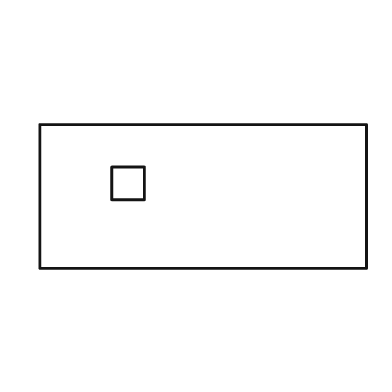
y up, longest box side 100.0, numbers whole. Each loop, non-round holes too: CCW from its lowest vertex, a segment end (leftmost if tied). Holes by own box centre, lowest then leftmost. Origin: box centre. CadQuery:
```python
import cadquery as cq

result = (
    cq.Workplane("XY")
    .moveTo(-50.0, -22.0)
    .lineTo(50.0, -22.0)
    .lineTo(50.0, 22.0)
    .lineTo(-50.0, 22.0)
    .close()
    .moveTo(-28.0, -1.0)
    .lineTo(-18.0, -1.0)
    .lineTo(-18.0, 9.0)
    .lineTo(-28.0, 9.0)
    .close()
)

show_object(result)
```